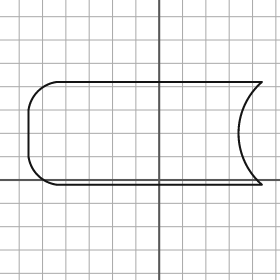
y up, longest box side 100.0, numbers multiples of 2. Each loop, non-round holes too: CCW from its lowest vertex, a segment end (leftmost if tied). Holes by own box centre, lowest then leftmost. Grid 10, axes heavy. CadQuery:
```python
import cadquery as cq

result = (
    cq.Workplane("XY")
    .moveTo(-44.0, -2.0)
    .lineTo(44.0, -2.0)
    .threePointArc((34.0, 20.0), (44.0, 42.0))
    .lineTo(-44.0, 42.0)
    .threePointArc((-52.0, 38.0), (-56.0, 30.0))
    .lineTo(-56.0, 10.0)
    .threePointArc((-52.0, 2.0), (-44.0, -2.0))
    .close()
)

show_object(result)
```